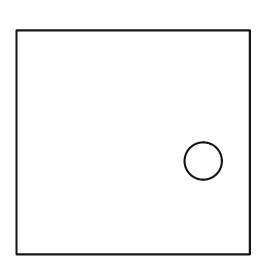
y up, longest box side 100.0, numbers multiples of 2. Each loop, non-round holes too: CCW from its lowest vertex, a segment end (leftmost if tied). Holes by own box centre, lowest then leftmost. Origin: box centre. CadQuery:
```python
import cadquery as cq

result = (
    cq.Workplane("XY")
    .moveTo(-50.0, -48.0)
    .lineTo(50.0, -48.0)
    .lineTo(50.0, 48.0)
    .lineTo(-50.0, 48.0)
    .close()
    .moveTo(30.0, -8.0)
    .circle(8.0)
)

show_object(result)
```